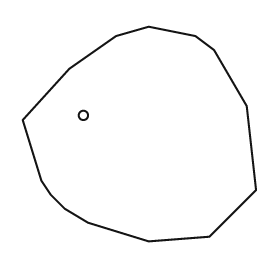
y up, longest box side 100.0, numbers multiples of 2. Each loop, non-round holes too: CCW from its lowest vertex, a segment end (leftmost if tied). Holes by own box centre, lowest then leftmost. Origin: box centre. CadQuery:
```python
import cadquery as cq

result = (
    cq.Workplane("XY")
    .moveTo(4.0, -46.0)
    .lineTo(30.0, -44.0)
    .lineTo(50.0, -24.0)
    .lineTo(46.0, 12.0)
    .lineTo(32.0, 36.0)
    .lineTo(24.0, 42.0)
    .lineTo(4.0, 46.0)
    .lineTo(-10.0, 42.0)
    .lineTo(-30.0, 28.0)
    .lineTo(-50.0, 6.0)
    .lineTo(-42.0, -20.0)
    .lineTo(-38.0, -26.0)
    .lineTo(-32.0, -32.0)
    .lineTo(-22.0, -38.0)
    .close()
    .moveTo(-24.0, 8.0)
    .circle(2.0)
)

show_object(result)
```